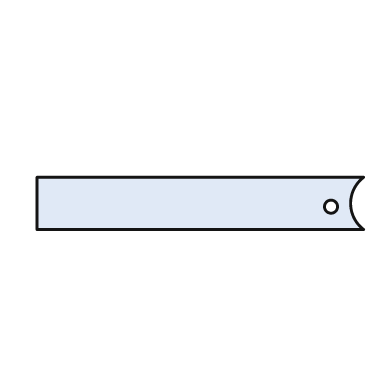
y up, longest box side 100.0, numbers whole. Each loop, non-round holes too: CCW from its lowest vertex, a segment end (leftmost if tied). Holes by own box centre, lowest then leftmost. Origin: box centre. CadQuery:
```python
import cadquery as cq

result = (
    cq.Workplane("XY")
    .moveTo(-50.0, -8.0)
    .lineTo(50.0, -8.0)
    .threePointArc((46.0, 0.0), (50.0, 8.0))
    .lineTo(-50.0, 8.0)
    .close()
    .moveTo(40.0, -1.0)
    .circle(2.0)
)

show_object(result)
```